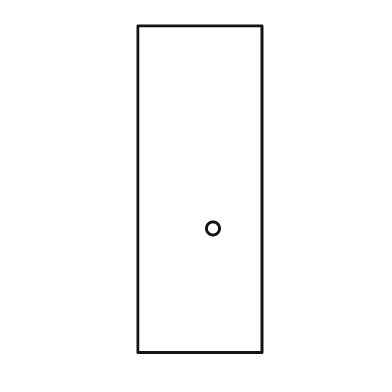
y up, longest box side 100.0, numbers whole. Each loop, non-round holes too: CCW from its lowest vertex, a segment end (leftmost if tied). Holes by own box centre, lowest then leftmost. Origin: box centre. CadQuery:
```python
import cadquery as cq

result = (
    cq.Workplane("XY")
    .moveTo(-19.0, -50.0)
    .lineTo(19.0, -50.0)
    .lineTo(19.0, 50.0)
    .lineTo(-19.0, 50.0)
    .close()
    .moveTo(4.0, -12.0)
    .circle(2.0)
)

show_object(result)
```